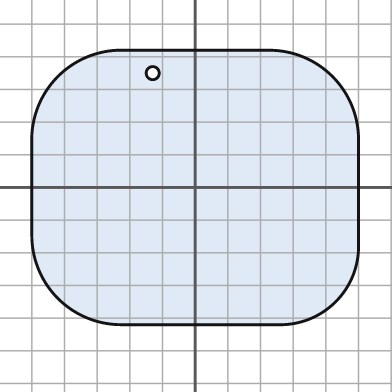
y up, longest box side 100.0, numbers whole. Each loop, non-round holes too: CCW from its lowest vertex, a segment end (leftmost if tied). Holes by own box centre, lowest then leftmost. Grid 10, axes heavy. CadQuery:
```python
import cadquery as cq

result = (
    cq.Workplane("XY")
    .moveTo(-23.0, -42.0)
    .lineTo(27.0, -42.0)
    .threePointArc((43.0, -35.0), (50.0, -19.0))
    .lineTo(50.0, 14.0)
    .threePointArc((42.0, 34.0), (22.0, 42.0))
    .lineTo(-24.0, 42.0)
    .threePointArc((-42.0, 34.0), (-50.0, 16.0))
    .lineTo(-50.0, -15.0)
    .threePointArc((-42.0, -34.0), (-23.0, -42.0))
    .close()
    .moveTo(-13.0, 35.0)
    .circle(2.0)
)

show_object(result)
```